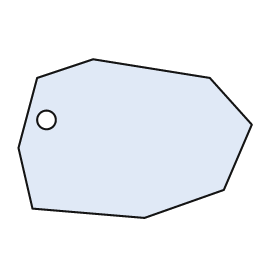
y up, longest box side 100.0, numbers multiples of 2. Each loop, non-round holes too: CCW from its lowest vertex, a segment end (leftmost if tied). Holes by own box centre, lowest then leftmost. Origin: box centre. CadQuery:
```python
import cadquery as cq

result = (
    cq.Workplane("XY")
    .moveTo(4.0, -34.0)
    .lineTo(38.0, -22.0)
    .lineTo(50.0, 6.0)
    .lineTo(32.0, 26.0)
    .lineTo(-18.0, 34.0)
    .lineTo(-42.0, 26.0)
    .lineTo(-50.0, -4.0)
    .lineTo(-44.0, -30.0)
    .close()
    .moveTo(-38.0, 8.0)
    .circle(4.0)
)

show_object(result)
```